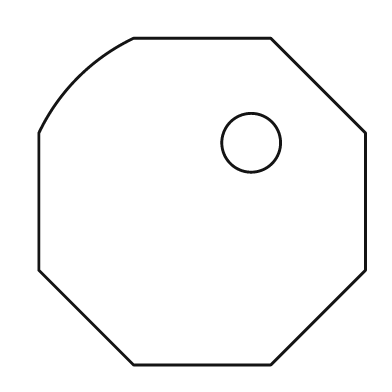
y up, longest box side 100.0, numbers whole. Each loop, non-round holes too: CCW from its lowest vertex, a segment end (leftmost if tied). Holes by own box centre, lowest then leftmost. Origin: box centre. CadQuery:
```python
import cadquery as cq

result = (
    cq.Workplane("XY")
    .moveTo(-21.0, -50.0)
    .lineTo(21.0, -50.0)
    .lineTo(50.0, -21.0)
    .lineTo(50.0, 21.0)
    .lineTo(21.0, 50.0)
    .lineTo(-21.0, 50.0)
    .threePointArc((-38.0, 38.0), (-50.0, 21.0))
    .lineTo(-50.0, -21.0)
    .close()
    .moveTo(15.0, 18.0)
    .circle(9.0)
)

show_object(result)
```